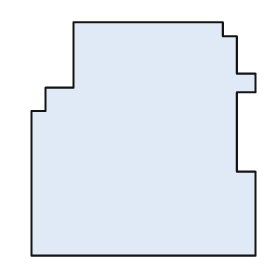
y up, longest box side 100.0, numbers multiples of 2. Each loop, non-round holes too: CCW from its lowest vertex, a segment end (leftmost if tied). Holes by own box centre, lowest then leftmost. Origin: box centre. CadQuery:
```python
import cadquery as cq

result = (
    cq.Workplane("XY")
    .moveTo(-48.0, -50.0)
    .lineTo(48.0, -50.0)
    .lineTo(48.0, -14.0)
    .lineTo(40.0, -14.0)
    .lineTo(40.0, 20.0)
    .lineTo(48.0, 20.0)
    .lineTo(48.0, 28.0)
    .lineTo(40.0, 28.0)
    .lineTo(40.0, 44.0)
    .lineTo(34.0, 44.0)
    .lineTo(34.0, 50.0)
    .lineTo(-30.0, 50.0)
    .lineTo(-30.0, 22.0)
    .lineTo(-42.0, 22.0)
    .lineTo(-42.0, 12.0)
    .lineTo(-48.0, 12.0)
    .close()
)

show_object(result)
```